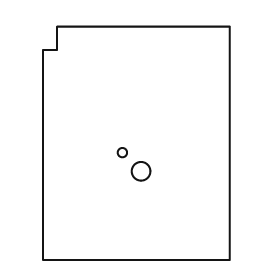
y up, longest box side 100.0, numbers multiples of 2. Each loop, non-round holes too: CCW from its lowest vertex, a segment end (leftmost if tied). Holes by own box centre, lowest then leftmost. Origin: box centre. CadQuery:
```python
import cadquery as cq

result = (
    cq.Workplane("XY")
    .moveTo(-40.0, -50.0)
    .lineTo(40.0, -50.0)
    .lineTo(40.0, 50.0)
    .lineTo(-34.0, 50.0)
    .lineTo(-34.0, 40.0)
    .lineTo(-40.0, 40.0)
    .close()
    .moveTo(2.0, -12.0)
    .circle(4.0)
    .moveTo(-6.0, -4.0)
    .circle(2.0)
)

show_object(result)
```